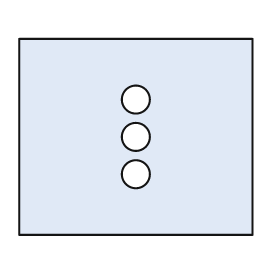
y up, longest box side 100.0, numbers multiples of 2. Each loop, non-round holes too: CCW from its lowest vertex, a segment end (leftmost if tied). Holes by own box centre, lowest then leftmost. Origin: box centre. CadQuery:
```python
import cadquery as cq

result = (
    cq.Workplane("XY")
    .moveTo(-50.0, -42.0)
    .lineTo(50.0, -42.0)
    .lineTo(50.0, 42.0)
    .lineTo(-50.0, 42.0)
    .close()
    .moveTo(0.0, -16.0)
    .circle(6.0)
    .moveTo(0.0, 0.0)
    .circle(6.0)
    .moveTo(0.0, 16.0)
    .circle(6.0)
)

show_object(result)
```